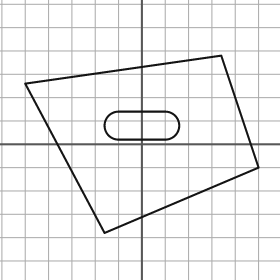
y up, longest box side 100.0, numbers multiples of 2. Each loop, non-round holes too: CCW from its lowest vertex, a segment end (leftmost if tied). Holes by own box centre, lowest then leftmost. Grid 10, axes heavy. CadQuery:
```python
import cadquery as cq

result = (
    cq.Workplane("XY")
    .moveTo(-16.0, -38.0)
    .lineTo(50.0, -10.0)
    .lineTo(34.0, 38.0)
    .lineTo(-50.0, 26.0)
    .close()
    .moveTo(-10.0, 2.0)
    .lineTo(10.0, 2.0)
    .threePointArc((16.0, 8.0), (10.0, 14.0))
    .lineTo(-10.0, 14.0)
    .threePointArc((-16.0, 8.0), (-10.0, 2.0))
    .close()
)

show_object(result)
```